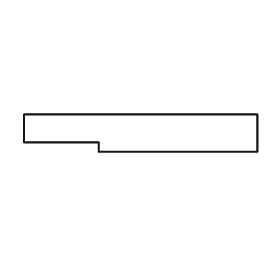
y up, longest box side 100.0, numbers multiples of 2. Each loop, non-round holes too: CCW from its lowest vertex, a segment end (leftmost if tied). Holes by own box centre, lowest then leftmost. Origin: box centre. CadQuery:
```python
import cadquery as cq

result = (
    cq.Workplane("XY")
    .moveTo(-18.0, -8.0)
    .lineTo(50.0, -8.0)
    .lineTo(50.0, 8.0)
    .lineTo(-50.0, 8.0)
    .lineTo(-50.0, -4.0)
    .lineTo(-18.0, -4.0)
    .close()
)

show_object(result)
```